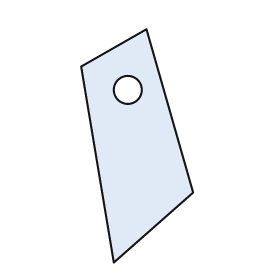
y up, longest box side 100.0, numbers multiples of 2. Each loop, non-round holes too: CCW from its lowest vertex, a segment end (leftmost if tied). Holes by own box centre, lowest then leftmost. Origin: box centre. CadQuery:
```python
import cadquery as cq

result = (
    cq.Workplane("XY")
    .moveTo(-10.0, -50.0)
    .lineTo(24.0, -20.0)
    .lineTo(4.0, 50.0)
    .lineTo(-24.0, 34.0)
    .close()
    .moveTo(-4.0, 24.0)
    .circle(6.0)
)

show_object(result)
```